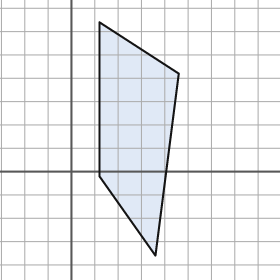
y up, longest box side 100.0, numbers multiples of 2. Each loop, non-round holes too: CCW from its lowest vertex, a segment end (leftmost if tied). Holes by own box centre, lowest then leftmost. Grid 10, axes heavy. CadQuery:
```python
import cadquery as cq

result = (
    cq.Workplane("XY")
    .moveTo(36.0, -36.0)
    .lineTo(46.0, 42.0)
    .lineTo(12.0, 64.0)
    .lineTo(12.0, -2.0)
    .close()
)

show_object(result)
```